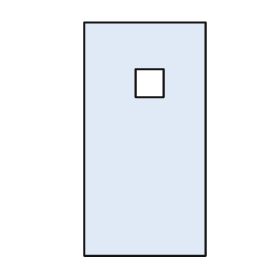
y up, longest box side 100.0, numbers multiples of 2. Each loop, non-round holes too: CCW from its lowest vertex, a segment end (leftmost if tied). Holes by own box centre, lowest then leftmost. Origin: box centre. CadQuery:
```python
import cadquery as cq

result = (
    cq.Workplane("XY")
    .moveTo(-26.0, -50.0)
    .lineTo(26.0, -50.0)
    .lineTo(26.0, 50.0)
    .lineTo(-26.0, 50.0)
    .close()
    .moveTo(-4.0, 18.0)
    .lineTo(8.0, 18.0)
    .lineTo(8.0, 30.0)
    .lineTo(-4.0, 30.0)
    .close()
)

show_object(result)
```